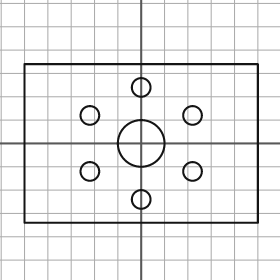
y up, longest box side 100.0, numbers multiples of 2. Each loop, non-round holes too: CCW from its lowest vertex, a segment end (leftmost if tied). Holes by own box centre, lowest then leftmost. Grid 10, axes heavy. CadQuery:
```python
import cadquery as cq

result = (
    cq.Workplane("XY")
    .moveTo(-50.0, -34.0)
    .lineTo(50.0, -34.0)
    .lineTo(50.0, 34.0)
    .lineTo(-50.0, 34.0)
    .close()
    .moveTo(0.0, -24.0)
    .circle(4.0)
    .moveTo(-22.0, -12.0)
    .circle(4.0)
    .moveTo(22.0, -12.0)
    .circle(4.0)
    .moveTo(0.0, 0.0)
    .circle(10.0)
    .moveTo(-22.0, 12.0)
    .circle(4.0)
    .moveTo(22.0, 12.0)
    .circle(4.0)
    .moveTo(0.0, 24.0)
    .circle(4.0)
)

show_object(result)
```